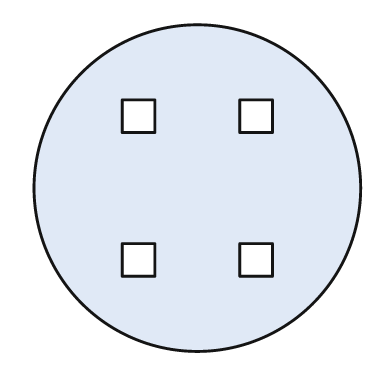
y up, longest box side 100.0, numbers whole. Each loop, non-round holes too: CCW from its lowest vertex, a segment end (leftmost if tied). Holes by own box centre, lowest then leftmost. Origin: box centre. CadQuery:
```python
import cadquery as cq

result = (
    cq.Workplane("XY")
    .moveTo(0.0, 0.0)
    .circle(50.0)
    .moveTo(-23.0, -27.0)
    .lineTo(-13.0, -27.0)
    .lineTo(-13.0, -17.0)
    .lineTo(-23.0, -17.0)
    .close()
    .moveTo(13.0, -27.0)
    .lineTo(23.0, -27.0)
    .lineTo(23.0, -17.0)
    .lineTo(13.0, -17.0)
    .close()
    .moveTo(-23.0, 17.0)
    .lineTo(-13.0, 17.0)
    .lineTo(-13.0, 27.0)
    .lineTo(-23.0, 27.0)
    .close()
    .moveTo(13.0, 17.0)
    .lineTo(23.0, 17.0)
    .lineTo(23.0, 27.0)
    .lineTo(13.0, 27.0)
    .close()
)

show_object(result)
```